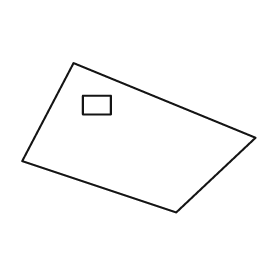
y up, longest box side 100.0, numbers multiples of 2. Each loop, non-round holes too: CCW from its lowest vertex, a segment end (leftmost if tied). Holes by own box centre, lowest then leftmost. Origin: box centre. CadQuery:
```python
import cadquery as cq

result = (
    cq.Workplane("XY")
    .moveTo(16.0, -32.0)
    .lineTo(50.0, 0.0)
    .lineTo(-28.0, 32.0)
    .lineTo(-50.0, -10.0)
    .close()
    .moveTo(-24.0, 10.0)
    .lineTo(-12.0, 10.0)
    .lineTo(-12.0, 18.0)
    .lineTo(-24.0, 18.0)
    .close()
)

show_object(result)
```